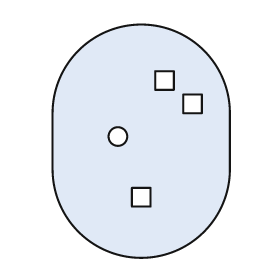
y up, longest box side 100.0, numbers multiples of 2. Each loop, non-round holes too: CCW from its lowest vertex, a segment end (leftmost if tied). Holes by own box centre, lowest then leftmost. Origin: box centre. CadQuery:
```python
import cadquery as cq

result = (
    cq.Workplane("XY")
    .moveTo(-38.0, -12.0)
    .threePointArc((0.0, -50.0), (38.0, -12.0))
    .lineTo(38.0, 12.0)
    .threePointArc((0.0, 50.0), (-38.0, 12.0))
    .close()
    .moveTo(-4.0, -28.0)
    .lineTo(4.0, -28.0)
    .lineTo(4.0, -20.0)
    .lineTo(-4.0, -20.0)
    .close()
    .moveTo(-10.0, 2.0)
    .circle(4.0)
    .moveTo(18.0, 12.0)
    .lineTo(26.0, 12.0)
    .lineTo(26.0, 20.0)
    .lineTo(18.0, 20.0)
    .close()
    .moveTo(6.0, 22.0)
    .lineTo(14.0, 22.0)
    .lineTo(14.0, 30.0)
    .lineTo(6.0, 30.0)
    .close()
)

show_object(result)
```